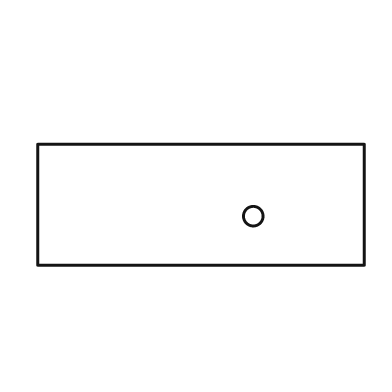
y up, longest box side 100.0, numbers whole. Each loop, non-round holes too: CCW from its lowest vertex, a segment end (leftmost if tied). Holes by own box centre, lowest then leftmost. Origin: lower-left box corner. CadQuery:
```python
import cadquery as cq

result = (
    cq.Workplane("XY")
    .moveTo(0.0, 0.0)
    .lineTo(100.0, 0.0)
    .lineTo(100.0, 37.0)
    .lineTo(0.0, 37.0)
    .close()
    .moveTo(66.0, 15.0)
    .circle(3.0)
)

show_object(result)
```